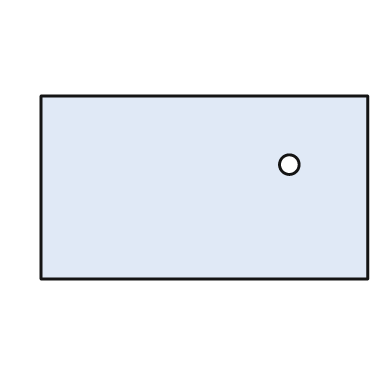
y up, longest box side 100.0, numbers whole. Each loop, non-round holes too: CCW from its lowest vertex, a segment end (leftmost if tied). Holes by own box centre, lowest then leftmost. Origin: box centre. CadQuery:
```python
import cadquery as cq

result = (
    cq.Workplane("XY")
    .moveTo(-50.0, -28.0)
    .lineTo(50.0, -28.0)
    .lineTo(50.0, 28.0)
    .lineTo(-50.0, 28.0)
    .close()
    .moveTo(26.0, 7.0)
    .circle(3.0)
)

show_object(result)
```